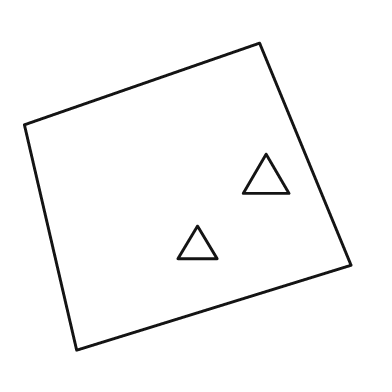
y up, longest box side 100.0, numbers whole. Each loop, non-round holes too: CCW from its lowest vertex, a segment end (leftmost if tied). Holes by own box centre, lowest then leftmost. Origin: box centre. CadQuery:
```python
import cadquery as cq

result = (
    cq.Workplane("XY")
    .moveTo(-34.0, -47.0)
    .lineTo(50.0, -21.0)
    .lineTo(22.0, 47.0)
    .lineTo(-50.0, 22.0)
    .close()
    .moveTo(-3.0, -19.0)
    .lineTo(9.0, -19.0)
    .lineTo(3.0, -9.0)
    .close()
    .moveTo(17.0, 1.0)
    .lineTo(31.0, 1.0)
    .lineTo(24.0, 13.0)
    .close()
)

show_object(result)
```